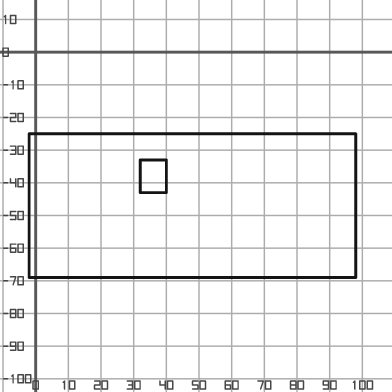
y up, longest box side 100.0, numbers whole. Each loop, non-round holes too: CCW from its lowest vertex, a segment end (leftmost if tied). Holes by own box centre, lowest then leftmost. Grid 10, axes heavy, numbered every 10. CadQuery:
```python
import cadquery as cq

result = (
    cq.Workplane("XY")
    .moveTo(-2.0, -69.0)
    .lineTo(98.0, -69.0)
    .lineTo(98.0, -25.0)
    .lineTo(-2.0, -25.0)
    .close()
    .moveTo(32.0, -43.0)
    .lineTo(40.0, -43.0)
    .lineTo(40.0, -33.0)
    .lineTo(32.0, -33.0)
    .close()
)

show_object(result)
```